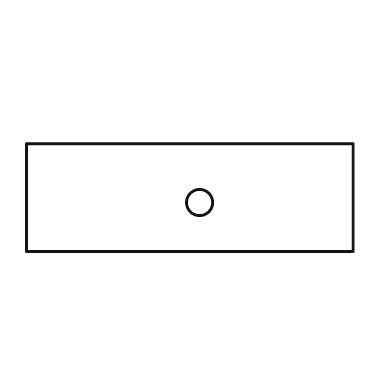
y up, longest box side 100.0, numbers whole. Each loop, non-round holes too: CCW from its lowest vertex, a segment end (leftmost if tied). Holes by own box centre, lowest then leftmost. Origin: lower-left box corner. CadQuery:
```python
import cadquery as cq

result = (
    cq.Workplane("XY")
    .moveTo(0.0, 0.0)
    .lineTo(100.0, 0.0)
    .lineTo(100.0, 33.0)
    .lineTo(0.0, 33.0)
    .close()
    .moveTo(53.0, 15.0)
    .circle(4.0)
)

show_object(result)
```